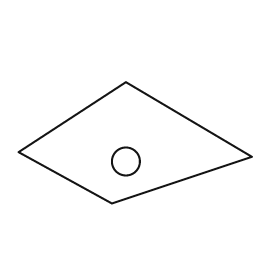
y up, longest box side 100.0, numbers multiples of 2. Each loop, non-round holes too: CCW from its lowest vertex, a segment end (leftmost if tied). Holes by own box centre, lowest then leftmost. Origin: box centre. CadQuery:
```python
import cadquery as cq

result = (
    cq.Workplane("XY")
    .moveTo(-10.0, -26.0)
    .lineTo(50.0, -6.0)
    .lineTo(-4.0, 26.0)
    .lineTo(-50.0, -4.0)
    .close()
    .moveTo(-4.0, -8.0)
    .circle(6.0)
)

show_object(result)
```